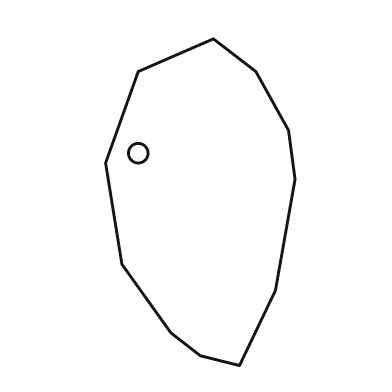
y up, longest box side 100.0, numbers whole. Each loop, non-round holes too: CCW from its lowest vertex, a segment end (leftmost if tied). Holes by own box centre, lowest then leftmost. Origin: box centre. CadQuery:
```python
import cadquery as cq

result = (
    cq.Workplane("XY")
    .moveTo(12.0, -50.0)
    .lineTo(23.0, -27.0)
    .lineTo(29.0, 7.0)
    .lineTo(27.0, 22.0)
    .lineTo(17.0, 40.0)
    .lineTo(4.0, 50.0)
    .lineTo(-19.0, 40.0)
    .lineTo(-29.0, 12.0)
    .lineTo(-24.0, -19.0)
    .lineTo(-9.0, -40.0)
    .lineTo(0.0, -47.0)
    .close()
    .moveTo(-19.0, 15.0)
    .circle(3.0)
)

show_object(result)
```